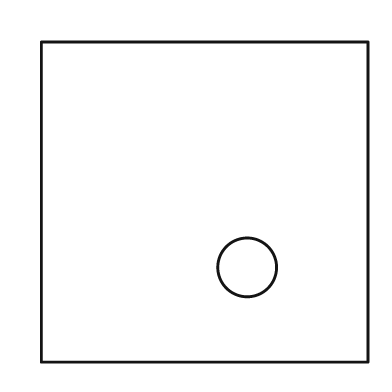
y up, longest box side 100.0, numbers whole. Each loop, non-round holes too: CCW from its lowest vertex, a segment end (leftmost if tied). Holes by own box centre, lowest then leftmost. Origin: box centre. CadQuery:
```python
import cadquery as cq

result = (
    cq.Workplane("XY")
    .moveTo(-50.0, -49.0)
    .lineTo(50.0, -49.0)
    .lineTo(50.0, 49.0)
    .lineTo(-50.0, 49.0)
    .close()
    .moveTo(13.0, -20.0)
    .circle(9.0)
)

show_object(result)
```